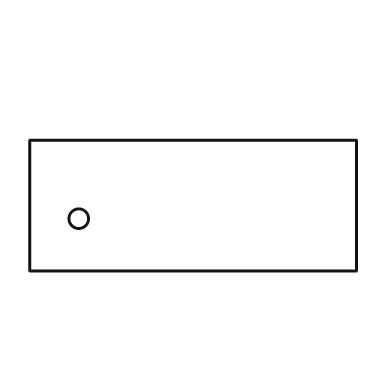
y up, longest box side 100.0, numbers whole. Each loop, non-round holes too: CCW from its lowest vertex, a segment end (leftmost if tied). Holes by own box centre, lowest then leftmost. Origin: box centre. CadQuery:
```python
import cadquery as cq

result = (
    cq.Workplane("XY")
    .moveTo(-50.0, -20.0)
    .lineTo(50.0, -20.0)
    .lineTo(50.0, 20.0)
    .lineTo(-50.0, 20.0)
    .close()
    .moveTo(-35.0, -4.0)
    .circle(3.0)
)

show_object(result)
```